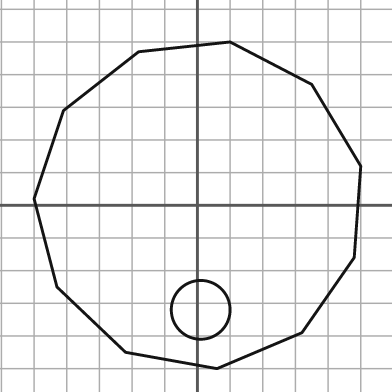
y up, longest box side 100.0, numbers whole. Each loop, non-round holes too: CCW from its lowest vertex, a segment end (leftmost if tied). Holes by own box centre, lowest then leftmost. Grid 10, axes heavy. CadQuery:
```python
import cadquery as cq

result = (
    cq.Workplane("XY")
    .moveTo(6.0, -50.0)
    .lineTo(32.0, -39.0)
    .lineTo(48.0, -16.0)
    .lineTo(50.0, 12.0)
    .lineTo(35.0, 37.0)
    .lineTo(10.0, 50.0)
    .lineTo(-18.0, 47.0)
    .lineTo(-41.0, 29.0)
    .lineTo(-50.0, 2.0)
    .lineTo(-43.0, -25.0)
    .lineTo(-22.0, -45.0)
    .close()
    .moveTo(1.0, -32.0)
    .circle(9.0)
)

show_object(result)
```